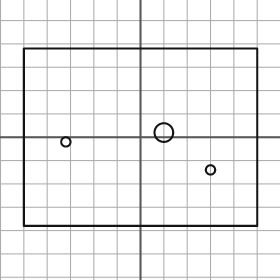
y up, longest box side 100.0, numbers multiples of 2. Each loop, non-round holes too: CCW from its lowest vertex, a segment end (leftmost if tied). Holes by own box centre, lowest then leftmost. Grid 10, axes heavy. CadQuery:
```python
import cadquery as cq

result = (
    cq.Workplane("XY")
    .moveTo(-50.0, -38.0)
    .lineTo(50.0, -38.0)
    .lineTo(50.0, 38.0)
    .lineTo(-50.0, 38.0)
    .close()
    .moveTo(30.0, -14.0)
    .circle(2.0)
    .moveTo(-32.0, -2.0)
    .circle(2.0)
    .moveTo(10.0, 2.0)
    .circle(4.0)
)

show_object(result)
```